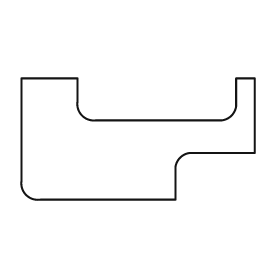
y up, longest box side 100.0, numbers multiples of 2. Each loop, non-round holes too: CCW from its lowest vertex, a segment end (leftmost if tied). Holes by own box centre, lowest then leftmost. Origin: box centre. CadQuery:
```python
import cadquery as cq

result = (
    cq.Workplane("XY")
    .moveTo(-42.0, -26.0)
    .lineTo(16.0, -26.0)
    .lineTo(16.0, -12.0)
    .threePointArc((18.0, -8.0), (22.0, -6.0))
    .lineTo(50.0, -6.0)
    .lineTo(50.0, 26.0)
    .lineTo(42.0, 26.0)
    .lineTo(42.0, 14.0)
    .threePointArc((40.0, 10.0), (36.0, 8.0))
    .lineTo(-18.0, 8.0)
    .threePointArc((-24.0, 10.0), (-26.0, 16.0))
    .lineTo(-26.0, 26.0)
    .lineTo(-50.0, 26.0)
    .lineTo(-50.0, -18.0)
    .threePointArc((-48.0, -24.0), (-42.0, -26.0))
    .close()
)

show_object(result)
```